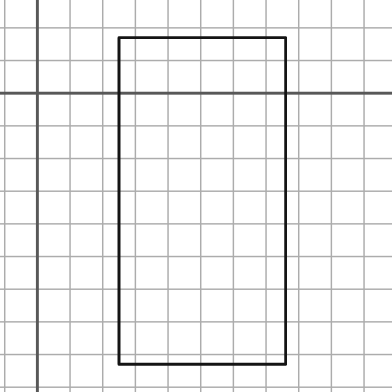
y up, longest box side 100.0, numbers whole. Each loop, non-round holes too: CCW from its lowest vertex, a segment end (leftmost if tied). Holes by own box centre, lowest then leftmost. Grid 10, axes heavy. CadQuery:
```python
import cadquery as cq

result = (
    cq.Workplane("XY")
    .moveTo(25.0, -83.0)
    .lineTo(76.0, -83.0)
    .lineTo(76.0, 17.0)
    .lineTo(25.0, 17.0)
    .close()
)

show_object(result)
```